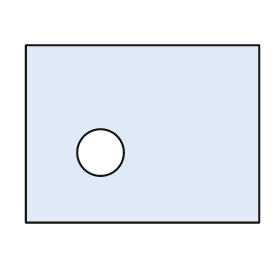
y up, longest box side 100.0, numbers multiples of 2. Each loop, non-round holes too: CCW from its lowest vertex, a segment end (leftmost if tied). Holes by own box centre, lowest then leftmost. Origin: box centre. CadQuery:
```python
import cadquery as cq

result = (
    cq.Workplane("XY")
    .moveTo(-50.0, -38.0)
    .lineTo(50.0, -38.0)
    .lineTo(50.0, 38.0)
    .lineTo(-50.0, 38.0)
    .close()
    .moveTo(-18.0, -8.0)
    .circle(10.0)
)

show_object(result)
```